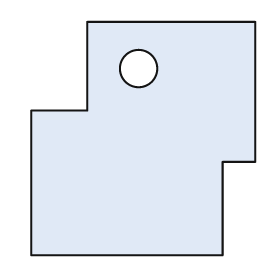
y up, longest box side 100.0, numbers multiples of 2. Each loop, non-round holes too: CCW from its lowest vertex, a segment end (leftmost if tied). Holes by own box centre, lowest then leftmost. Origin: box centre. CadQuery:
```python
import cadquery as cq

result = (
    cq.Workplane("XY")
    .moveTo(-48.0, -50.0)
    .lineTo(34.0, -50.0)
    .lineTo(34.0, -10.0)
    .lineTo(48.0, -10.0)
    .lineTo(48.0, 50.0)
    .lineTo(-24.0, 50.0)
    .lineTo(-24.0, 12.0)
    .lineTo(-48.0, 12.0)
    .close()
    .moveTo(-2.0, 30.0)
    .circle(8.0)
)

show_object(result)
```